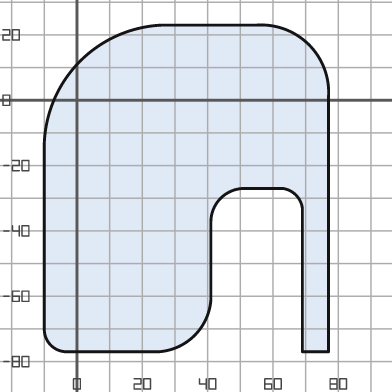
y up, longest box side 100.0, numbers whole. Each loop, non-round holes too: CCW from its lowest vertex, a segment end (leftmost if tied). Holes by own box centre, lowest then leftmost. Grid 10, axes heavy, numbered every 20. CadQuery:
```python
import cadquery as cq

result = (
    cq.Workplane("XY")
    .moveTo(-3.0, -77.0)
    .lineTo(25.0, -77.0)
    .threePointArc((36.0, -72.0), (41.0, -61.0))
    .lineTo(41.0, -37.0)
    .threePointArc((44.0, -30.0), (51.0, -27.0))
    .lineTo(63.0, -27.0)
    .threePointArc((67.0, -29.0), (69.0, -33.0))
    .lineTo(69.0, -77.0)
    .lineTo(77.0, -77.0)
    .lineTo(77.0, 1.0)
    .threePointArc((71.0, 17.0), (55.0, 23.0))
    .lineTo(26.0, 23.0)
    .threePointArc((1.0, 12.0), (-10.0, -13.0))
    .lineTo(-10.0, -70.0)
    .threePointArc((-8.0, -75.0), (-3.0, -77.0))
    .close()
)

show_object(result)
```